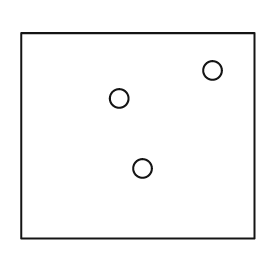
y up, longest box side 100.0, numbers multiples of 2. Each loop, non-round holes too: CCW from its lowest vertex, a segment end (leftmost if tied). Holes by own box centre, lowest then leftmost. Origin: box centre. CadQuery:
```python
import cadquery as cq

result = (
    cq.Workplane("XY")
    .moveTo(-50.0, -44.0)
    .lineTo(50.0, -44.0)
    .lineTo(50.0, 44.0)
    .lineTo(-50.0, 44.0)
    .close()
    .moveTo(2.0, -14.0)
    .circle(4.0)
    .moveTo(-8.0, 16.0)
    .circle(4.0)
    .moveTo(32.0, 28.0)
    .circle(4.0)
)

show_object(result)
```